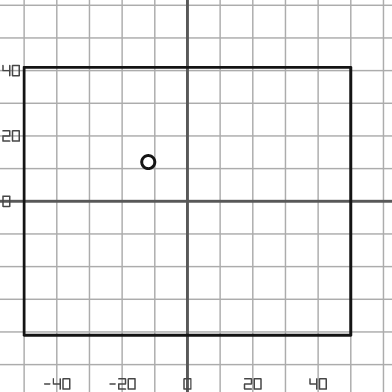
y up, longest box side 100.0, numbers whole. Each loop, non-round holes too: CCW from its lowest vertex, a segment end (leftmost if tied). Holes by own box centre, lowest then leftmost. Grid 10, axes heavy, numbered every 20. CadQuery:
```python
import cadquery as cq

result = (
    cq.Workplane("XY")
    .moveTo(-50.0, -41.0)
    .lineTo(50.0, -41.0)
    .lineTo(50.0, 41.0)
    .lineTo(-50.0, 41.0)
    .close()
    .moveTo(-12.0, 12.0)
    .circle(2.0)
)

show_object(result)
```